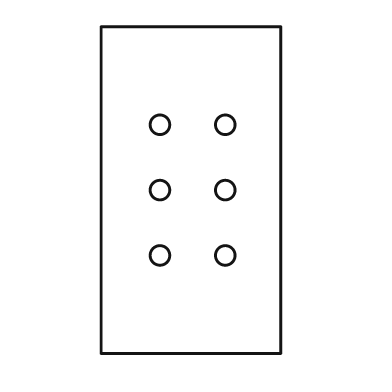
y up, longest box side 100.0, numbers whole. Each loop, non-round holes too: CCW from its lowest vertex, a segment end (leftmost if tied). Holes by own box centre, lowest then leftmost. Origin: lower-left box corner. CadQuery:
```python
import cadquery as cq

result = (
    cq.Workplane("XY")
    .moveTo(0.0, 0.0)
    .lineTo(55.0, 0.0)
    .lineTo(55.0, 100.0)
    .lineTo(0.0, 100.0)
    .close()
    .moveTo(18.0, 30.0)
    .circle(3.0)
    .moveTo(38.0, 30.0)
    .circle(3.0)
    .moveTo(18.0, 50.0)
    .circle(3.0)
    .moveTo(38.0, 50.0)
    .circle(3.0)
    .moveTo(18.0, 70.0)
    .circle(3.0)
    .moveTo(38.0, 70.0)
    .circle(3.0)
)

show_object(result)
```